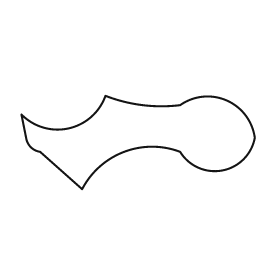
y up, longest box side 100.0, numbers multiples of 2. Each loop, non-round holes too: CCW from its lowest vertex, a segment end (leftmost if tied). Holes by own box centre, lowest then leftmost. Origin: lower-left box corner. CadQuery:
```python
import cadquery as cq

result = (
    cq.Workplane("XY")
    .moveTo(26.0, 0.0)
    .threePointArc((44.0, 16.0), (68.0, 16.0))
    .threePointArc((86.0, 8.0), (100.0, 22.0))
    .threePointArc((88.0, 38.0), (68.0, 36.0))
    .threePointArc((52.0, 36.0), (36.0, 40.0))
    .threePointArc((20.0, 26.0), (0.0, 32.0))
    .lineTo(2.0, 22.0)
    .threePointArc((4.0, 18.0), (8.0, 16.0))
    .close()
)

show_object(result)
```